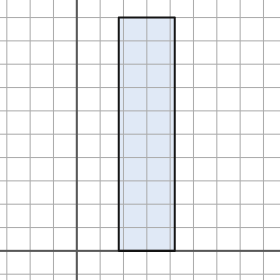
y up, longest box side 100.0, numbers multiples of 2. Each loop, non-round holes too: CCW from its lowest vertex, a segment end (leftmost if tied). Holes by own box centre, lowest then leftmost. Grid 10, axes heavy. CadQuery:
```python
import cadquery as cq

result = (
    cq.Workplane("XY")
    .moveTo(18.0, 0.0)
    .lineTo(42.0, 0.0)
    .lineTo(42.0, 100.0)
    .lineTo(18.0, 100.0)
    .close()
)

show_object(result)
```